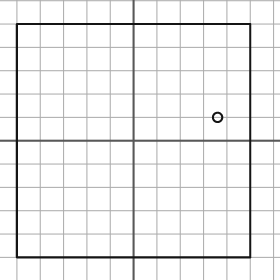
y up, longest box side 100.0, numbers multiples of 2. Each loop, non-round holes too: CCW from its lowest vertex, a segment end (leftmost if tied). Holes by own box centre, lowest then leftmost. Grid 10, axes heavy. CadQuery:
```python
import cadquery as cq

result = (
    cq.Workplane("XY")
    .moveTo(-50.0, -50.0)
    .lineTo(50.0, -50.0)
    .lineTo(50.0, 50.0)
    .lineTo(-50.0, 50.0)
    .close()
    .moveTo(36.0, 10.0)
    .circle(2.0)
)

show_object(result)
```